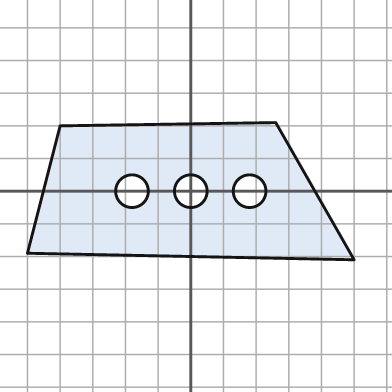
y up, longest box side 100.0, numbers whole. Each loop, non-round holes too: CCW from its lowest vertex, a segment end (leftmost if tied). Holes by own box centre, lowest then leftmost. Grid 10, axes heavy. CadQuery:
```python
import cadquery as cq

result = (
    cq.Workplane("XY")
    .moveTo(50.0, -21.0)
    .lineTo(26.0, 21.0)
    .lineTo(-40.0, 20.0)
    .lineTo(-50.0, -19.0)
    .close()
    .moveTo(-18.0, 0.0)
    .circle(5.0)
    .moveTo(0.0, 0.0)
    .circle(5.0)
    .moveTo(18.0, 0.0)
    .circle(5.0)
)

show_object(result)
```